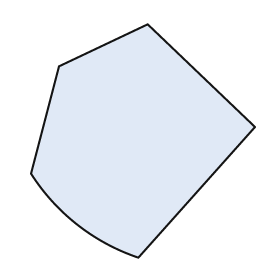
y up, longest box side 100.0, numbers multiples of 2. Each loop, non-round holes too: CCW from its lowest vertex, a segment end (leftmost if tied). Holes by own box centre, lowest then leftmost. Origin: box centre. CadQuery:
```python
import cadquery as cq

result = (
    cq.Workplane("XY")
    .moveTo(-2.0, -50.0)
    .lineTo(48.0, 6.0)
    .lineTo(2.0, 50.0)
    .lineTo(-36.0, 32.0)
    .lineTo(-48.0, -14.0)
    .threePointArc((-28.0, -36.0), (-2.0, -50.0))
    .close()
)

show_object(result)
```